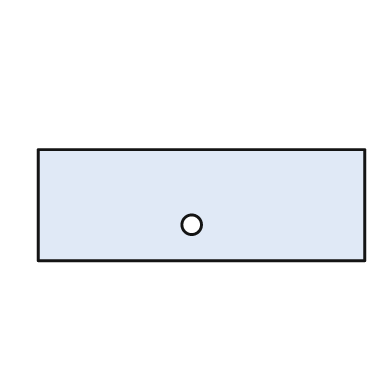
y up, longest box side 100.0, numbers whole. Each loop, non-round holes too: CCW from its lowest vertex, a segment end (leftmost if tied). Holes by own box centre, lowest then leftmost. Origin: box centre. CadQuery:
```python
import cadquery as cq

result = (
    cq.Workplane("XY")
    .moveTo(-50.0, -17.0)
    .lineTo(50.0, -17.0)
    .lineTo(50.0, 17.0)
    .lineTo(-50.0, 17.0)
    .close()
    .moveTo(-3.0, -6.0)
    .circle(3.0)
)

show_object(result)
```